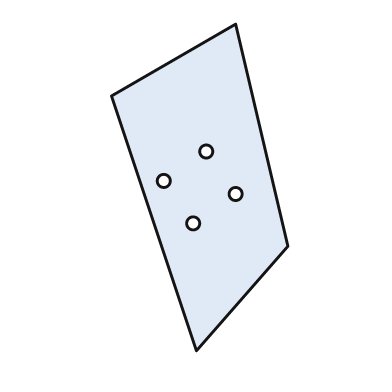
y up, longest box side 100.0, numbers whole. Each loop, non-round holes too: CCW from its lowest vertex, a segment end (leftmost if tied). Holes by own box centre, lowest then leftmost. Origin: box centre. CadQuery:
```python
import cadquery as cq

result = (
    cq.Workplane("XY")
    .moveTo(-1.0, -50.0)
    .lineTo(27.0, -18.0)
    .lineTo(11.0, 50.0)
    .lineTo(-27.0, 28.0)
    .close()
    .moveTo(-2.0, -11.0)
    .circle(2.0)
    .moveTo(11.0, -2.0)
    .circle(2.0)
    .moveTo(-11.0, 2.0)
    .circle(2.0)
    .moveTo(2.0, 11.0)
    .circle(2.0)
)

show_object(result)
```